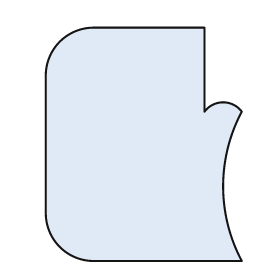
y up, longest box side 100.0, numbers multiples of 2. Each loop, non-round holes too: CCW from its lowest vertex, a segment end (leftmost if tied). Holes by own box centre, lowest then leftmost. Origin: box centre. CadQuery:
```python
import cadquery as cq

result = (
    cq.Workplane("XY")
    .moveTo(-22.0, -50.0)
    .lineTo(42.0, -50.0)
    .threePointArc((34.0, -18.0), (42.0, 14.0))
    .threePointArc((34.0, 18.0), (26.0, 14.0))
    .lineTo(26.0, 50.0)
    .lineTo(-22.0, 50.0)
    .threePointArc((-36.0, 44.0), (-42.0, 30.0))
    .lineTo(-42.0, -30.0)
    .threePointArc((-36.0, -44.0), (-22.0, -50.0))
    .close()
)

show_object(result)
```